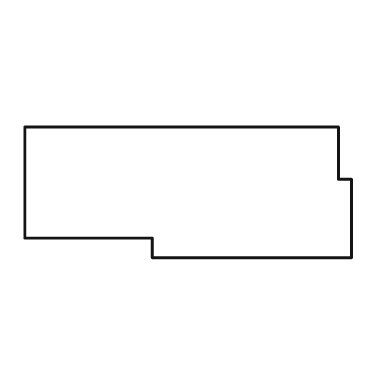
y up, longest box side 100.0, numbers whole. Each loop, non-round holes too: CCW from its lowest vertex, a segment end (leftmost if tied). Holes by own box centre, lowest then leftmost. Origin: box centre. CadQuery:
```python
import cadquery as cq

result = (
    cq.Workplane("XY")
    .moveTo(-11.0, -20.0)
    .lineTo(50.0, -20.0)
    .lineTo(50.0, 4.0)
    .lineTo(46.0, 4.0)
    .lineTo(46.0, 20.0)
    .lineTo(-50.0, 20.0)
    .lineTo(-50.0, -14.0)
    .lineTo(-11.0, -14.0)
    .close()
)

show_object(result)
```